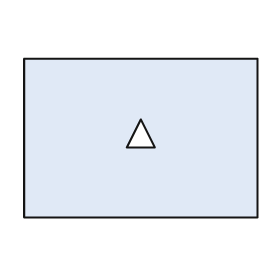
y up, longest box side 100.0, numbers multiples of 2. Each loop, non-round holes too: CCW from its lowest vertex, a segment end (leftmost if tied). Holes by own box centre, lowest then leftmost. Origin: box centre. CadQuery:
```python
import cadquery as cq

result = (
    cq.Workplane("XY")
    .moveTo(-50.0, -34.0)
    .lineTo(50.0, -34.0)
    .lineTo(50.0, 34.0)
    .lineTo(-50.0, 34.0)
    .close()
    .moveTo(-6.0, -4.0)
    .lineTo(6.0, -4.0)
    .lineTo(0.0, 8.0)
    .close()
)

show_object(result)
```